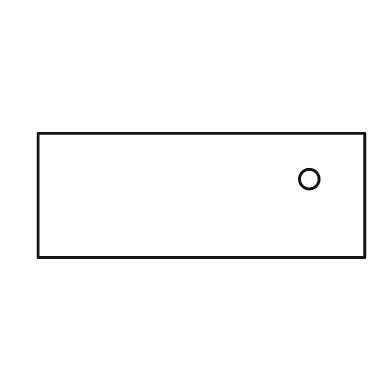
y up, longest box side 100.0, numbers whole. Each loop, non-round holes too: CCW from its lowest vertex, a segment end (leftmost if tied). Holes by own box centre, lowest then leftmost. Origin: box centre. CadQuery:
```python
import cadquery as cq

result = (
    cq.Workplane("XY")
    .moveTo(-50.0, -19.0)
    .lineTo(50.0, -19.0)
    .lineTo(50.0, 19.0)
    .lineTo(-50.0, 19.0)
    .close()
    .moveTo(33.0, 5.0)
    .circle(3.0)
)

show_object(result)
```